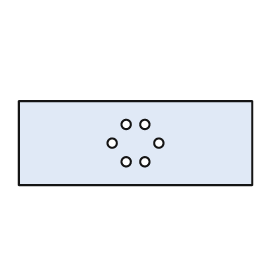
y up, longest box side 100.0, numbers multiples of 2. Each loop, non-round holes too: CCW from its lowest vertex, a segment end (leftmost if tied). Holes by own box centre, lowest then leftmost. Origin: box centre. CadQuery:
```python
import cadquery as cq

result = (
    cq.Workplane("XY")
    .moveTo(-50.0, -18.0)
    .lineTo(50.0, -18.0)
    .lineTo(50.0, 18.0)
    .lineTo(-50.0, 18.0)
    .close()
    .moveTo(-4.0, -8.0)
    .circle(2.0)
    .moveTo(4.0, -8.0)
    .circle(2.0)
    .moveTo(-10.0, 0.0)
    .circle(2.0)
    .moveTo(10.0, 0.0)
    .circle(2.0)
    .moveTo(-4.0, 8.0)
    .circle(2.0)
    .moveTo(4.0, 8.0)
    .circle(2.0)
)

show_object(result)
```